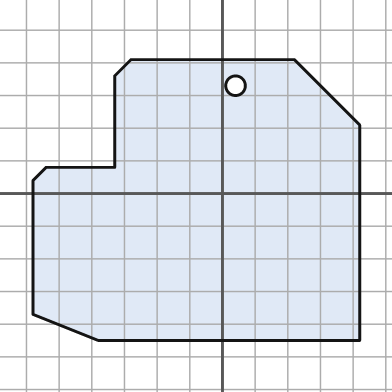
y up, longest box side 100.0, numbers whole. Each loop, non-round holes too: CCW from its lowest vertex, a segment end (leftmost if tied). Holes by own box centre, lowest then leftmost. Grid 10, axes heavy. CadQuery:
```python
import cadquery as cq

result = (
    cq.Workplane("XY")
    .moveTo(-38.0, -45.0)
    .lineTo(42.0, -45.0)
    .lineTo(42.0, 21.0)
    .lineTo(22.0, 41.0)
    .lineTo(-28.0, 41.0)
    .lineTo(-33.0, 36.0)
    .lineTo(-33.0, 8.0)
    .lineTo(-54.0, 8.0)
    .lineTo(-58.0, 4.0)
    .lineTo(-58.0, -37.0)
    .close()
    .moveTo(4.0, 33.0)
    .circle(3.0)
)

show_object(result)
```